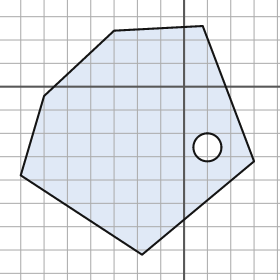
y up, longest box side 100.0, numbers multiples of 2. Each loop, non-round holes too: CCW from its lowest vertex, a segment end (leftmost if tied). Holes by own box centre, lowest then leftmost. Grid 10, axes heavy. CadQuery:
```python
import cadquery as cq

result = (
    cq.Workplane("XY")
    .moveTo(-18.0, -72.0)
    .lineTo(30.0, -32.0)
    .lineTo(8.0, 26.0)
    .lineTo(-30.0, 24.0)
    .lineTo(-60.0, -4.0)
    .lineTo(-70.0, -38.0)
    .close()
    .moveTo(10.0, -26.0)
    .circle(6.0)
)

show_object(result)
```